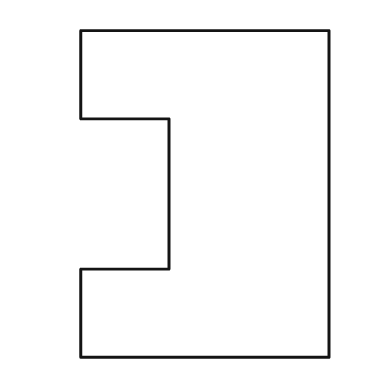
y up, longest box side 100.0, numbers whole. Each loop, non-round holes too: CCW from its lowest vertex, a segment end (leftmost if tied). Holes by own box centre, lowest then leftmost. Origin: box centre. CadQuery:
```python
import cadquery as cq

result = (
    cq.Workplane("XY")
    .moveTo(-38.0, -50.0)
    .lineTo(38.0, -50.0)
    .lineTo(38.0, 50.0)
    .lineTo(-38.0, 50.0)
    .lineTo(-38.0, 23.0)
    .lineTo(-11.0, 23.0)
    .lineTo(-11.0, -23.0)
    .lineTo(-38.0, -23.0)
    .close()
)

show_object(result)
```